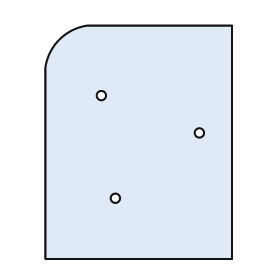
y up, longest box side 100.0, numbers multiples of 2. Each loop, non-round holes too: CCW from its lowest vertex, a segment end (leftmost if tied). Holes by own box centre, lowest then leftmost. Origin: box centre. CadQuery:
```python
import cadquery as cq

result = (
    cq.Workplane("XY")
    .moveTo(-40.0, -50.0)
    .lineTo(40.0, -50.0)
    .lineTo(40.0, 50.0)
    .lineTo(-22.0, 50.0)
    .threePointArc((-34.0, 44.0), (-40.0, 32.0))
    .close()
    .moveTo(-10.0, -24.0)
    .circle(2.0)
    .moveTo(26.0, 4.0)
    .circle(2.0)
    .moveTo(-16.0, 20.0)
    .circle(2.0)
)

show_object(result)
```